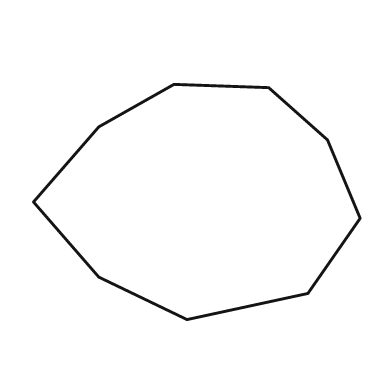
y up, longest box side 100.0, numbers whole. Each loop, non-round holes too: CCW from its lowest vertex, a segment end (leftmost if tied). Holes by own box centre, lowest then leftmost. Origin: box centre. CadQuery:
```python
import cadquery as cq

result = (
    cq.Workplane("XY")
    .moveTo(-3.0, -36.0)
    .lineTo(34.0, -28.0)
    .lineTo(50.0, -5.0)
    .lineTo(40.0, 19.0)
    .lineTo(22.0, 35.0)
    .lineTo(-7.0, 36.0)
    .lineTo(-30.0, 23.0)
    .lineTo(-50.0, 0.0)
    .lineTo(-30.0, -23.0)
    .close()
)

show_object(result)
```